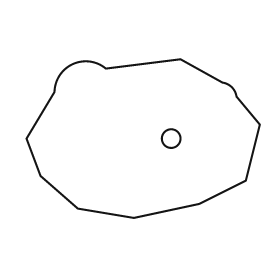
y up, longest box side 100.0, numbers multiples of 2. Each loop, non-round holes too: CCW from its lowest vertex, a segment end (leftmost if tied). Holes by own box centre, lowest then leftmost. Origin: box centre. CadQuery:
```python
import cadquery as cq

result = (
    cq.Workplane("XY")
    .moveTo(-4.0, -34.0)
    .lineTo(24.0, -28.0)
    .lineTo(44.0, -18.0)
    .lineTo(50.0, 6.0)
    .lineTo(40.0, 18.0)
    .threePointArc((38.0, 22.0), (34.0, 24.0))
    .lineTo(16.0, 34.0)
    .lineTo(-16.0, 30.0)
    .threePointArc((-30.0, 32.0), (-38.0, 20.0))
    .lineTo(-50.0, 0.0)
    .lineTo(-44.0, -16.0)
    .lineTo(-28.0, -30.0)
    .close()
    .moveTo(12.0, 0.0)
    .circle(4.0)
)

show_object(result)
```